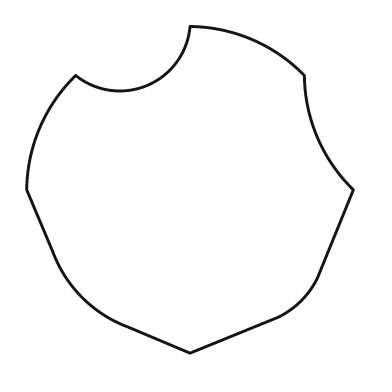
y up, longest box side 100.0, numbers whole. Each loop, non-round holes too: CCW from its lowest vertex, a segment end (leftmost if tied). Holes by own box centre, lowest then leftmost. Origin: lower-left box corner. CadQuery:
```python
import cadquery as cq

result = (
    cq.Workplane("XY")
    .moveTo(50.0, 0.0)
    .lineTo(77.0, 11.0)
    .threePointArc((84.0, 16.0), (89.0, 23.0))
    .lineTo(100.0, 50.0)
    .threePointArc((89.0, 66.0), (85.0, 85.0))
    .threePointArc((69.0, 96.0), (50.0, 100.0))
    .threePointArc((37.0, 82.0), (15.0, 85.0))
    .threePointArc((4.0, 69.0), (0.0, 50.0))
    .lineTo(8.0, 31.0)
    .threePointArc((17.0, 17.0), (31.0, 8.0))
    .close()
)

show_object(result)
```